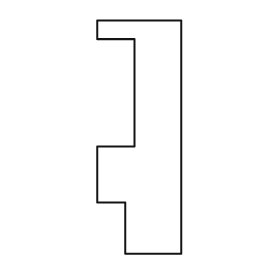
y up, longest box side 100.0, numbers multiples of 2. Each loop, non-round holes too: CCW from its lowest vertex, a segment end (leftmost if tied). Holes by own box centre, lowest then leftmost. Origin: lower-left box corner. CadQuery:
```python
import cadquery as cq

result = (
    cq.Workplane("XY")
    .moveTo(12.0, 0.0)
    .lineTo(36.0, 0.0)
    .lineTo(36.0, 100.0)
    .lineTo(0.0, 100.0)
    .lineTo(0.0, 92.0)
    .lineTo(16.0, 92.0)
    .lineTo(16.0, 46.0)
    .lineTo(0.0, 46.0)
    .lineTo(0.0, 22.0)
    .lineTo(12.0, 22.0)
    .close()
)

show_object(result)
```